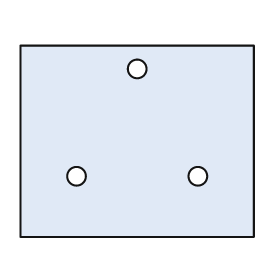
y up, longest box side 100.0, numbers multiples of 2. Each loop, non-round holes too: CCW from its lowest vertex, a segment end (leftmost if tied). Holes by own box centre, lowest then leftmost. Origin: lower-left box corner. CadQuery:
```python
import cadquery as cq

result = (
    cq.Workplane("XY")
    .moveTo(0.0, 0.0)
    .lineTo(100.0, 0.0)
    .lineTo(100.0, 82.0)
    .lineTo(0.0, 82.0)
    .close()
    .moveTo(24.0, 26.0)
    .circle(4.0)
    .moveTo(76.0, 26.0)
    .circle(4.0)
    .moveTo(50.0, 72.0)
    .circle(4.0)
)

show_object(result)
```